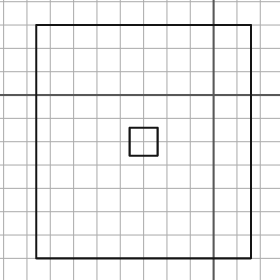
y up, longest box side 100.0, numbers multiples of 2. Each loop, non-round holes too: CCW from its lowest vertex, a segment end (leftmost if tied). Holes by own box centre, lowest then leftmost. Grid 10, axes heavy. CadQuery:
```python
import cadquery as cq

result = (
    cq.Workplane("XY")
    .moveTo(-76.0, -70.0)
    .lineTo(16.0, -70.0)
    .lineTo(16.0, 30.0)
    .lineTo(-76.0, 30.0)
    .close()
    .moveTo(-36.0, -26.0)
    .lineTo(-24.0, -26.0)
    .lineTo(-24.0, -14.0)
    .lineTo(-36.0, -14.0)
    .close()
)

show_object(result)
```